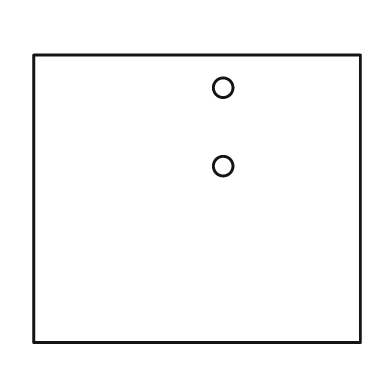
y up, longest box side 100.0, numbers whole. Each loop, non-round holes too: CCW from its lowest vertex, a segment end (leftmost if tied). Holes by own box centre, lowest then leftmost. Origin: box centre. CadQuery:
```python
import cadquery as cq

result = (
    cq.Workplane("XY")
    .moveTo(-50.0, -44.0)
    .lineTo(50.0, -44.0)
    .lineTo(50.0, 44.0)
    .lineTo(-50.0, 44.0)
    .close()
    .moveTo(8.0, 10.0)
    .circle(3.0)
    .moveTo(8.0, 34.0)
    .circle(3.0)
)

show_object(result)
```